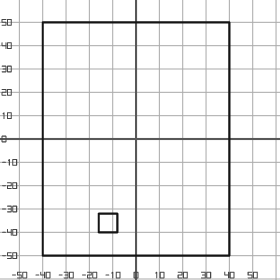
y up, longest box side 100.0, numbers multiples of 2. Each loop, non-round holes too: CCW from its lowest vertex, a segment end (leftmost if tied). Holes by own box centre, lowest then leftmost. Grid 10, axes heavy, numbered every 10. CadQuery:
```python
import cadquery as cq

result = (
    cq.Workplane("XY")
    .moveTo(-40.0, -50.0)
    .lineTo(40.0, -50.0)
    .lineTo(40.0, 50.0)
    .lineTo(-40.0, 50.0)
    .close()
    .moveTo(-16.0, -40.0)
    .lineTo(-8.0, -40.0)
    .lineTo(-8.0, -32.0)
    .lineTo(-16.0, -32.0)
    .close()
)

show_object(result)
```